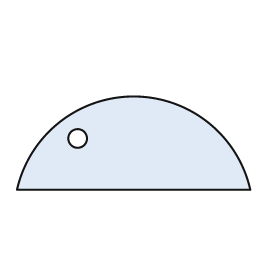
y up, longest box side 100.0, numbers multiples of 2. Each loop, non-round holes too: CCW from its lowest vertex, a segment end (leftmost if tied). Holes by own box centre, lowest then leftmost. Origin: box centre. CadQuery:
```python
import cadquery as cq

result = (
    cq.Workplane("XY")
    .moveTo(-50.0, -20.0)
    .lineTo(50.0, -20.0)
    .threePointArc((0.0, 20.0), (-50.0, -20.0))
    .close()
    .moveTo(-24.0, 2.0)
    .circle(4.0)
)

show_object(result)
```